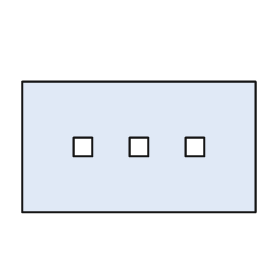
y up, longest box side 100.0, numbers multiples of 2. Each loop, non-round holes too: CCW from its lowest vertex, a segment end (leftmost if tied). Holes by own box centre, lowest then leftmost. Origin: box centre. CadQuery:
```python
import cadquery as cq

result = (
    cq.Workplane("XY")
    .moveTo(-50.0, -28.0)
    .lineTo(50.0, -28.0)
    .lineTo(50.0, 28.0)
    .lineTo(-50.0, 28.0)
    .close()
    .moveTo(-28.0, -4.0)
    .lineTo(-20.0, -4.0)
    .lineTo(-20.0, 4.0)
    .lineTo(-28.0, 4.0)
    .close()
    .moveTo(-4.0, -4.0)
    .lineTo(4.0, -4.0)
    .lineTo(4.0, 4.0)
    .lineTo(-4.0, 4.0)
    .close()
    .moveTo(20.0, -4.0)
    .lineTo(28.0, -4.0)
    .lineTo(28.0, 4.0)
    .lineTo(20.0, 4.0)
    .close()
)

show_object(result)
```